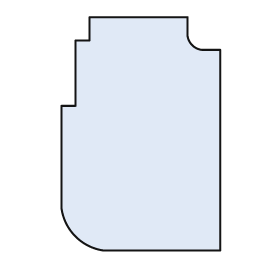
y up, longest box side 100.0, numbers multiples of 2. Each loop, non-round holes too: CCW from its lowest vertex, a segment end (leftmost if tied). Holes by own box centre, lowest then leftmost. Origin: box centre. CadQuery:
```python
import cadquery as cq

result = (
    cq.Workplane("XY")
    .moveTo(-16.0, -50.0)
    .lineTo(34.0, -50.0)
    .lineTo(34.0, 36.0)
    .lineTo(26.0, 36.0)
    .threePointArc((22.0, 38.0), (20.0, 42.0))
    .lineTo(20.0, 50.0)
    .lineTo(-22.0, 50.0)
    .lineTo(-22.0, 40.0)
    .lineTo(-28.0, 40.0)
    .lineTo(-28.0, 12.0)
    .lineTo(-34.0, 12.0)
    .lineTo(-34.0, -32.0)
    .threePointArc((-28.0, -44.0), (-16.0, -50.0))
    .close()
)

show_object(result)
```